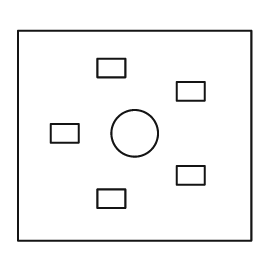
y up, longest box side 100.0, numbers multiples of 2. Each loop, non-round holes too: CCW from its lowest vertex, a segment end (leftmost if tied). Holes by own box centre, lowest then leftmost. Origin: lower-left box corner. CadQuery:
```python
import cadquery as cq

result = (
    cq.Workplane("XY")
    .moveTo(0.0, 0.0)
    .lineTo(100.0, 0.0)
    .lineTo(100.0, 90.0)
    .lineTo(0.0, 90.0)
    .close()
    .moveTo(34.0, 14.0)
    .lineTo(46.0, 14.0)
    .lineTo(46.0, 22.0)
    .lineTo(34.0, 22.0)
    .close()
    .moveTo(68.0, 24.0)
    .lineTo(80.0, 24.0)
    .lineTo(80.0, 32.0)
    .lineTo(68.0, 32.0)
    .close()
    .moveTo(14.0, 42.0)
    .lineTo(26.0, 42.0)
    .lineTo(26.0, 50.0)
    .lineTo(14.0, 50.0)
    .close()
    .moveTo(50.0, 46.0)
    .circle(10.0)
    .moveTo(68.0, 60.0)
    .lineTo(80.0, 60.0)
    .lineTo(80.0, 68.0)
    .lineTo(68.0, 68.0)
    .close()
    .moveTo(34.0, 70.0)
    .lineTo(46.0, 70.0)
    .lineTo(46.0, 78.0)
    .lineTo(34.0, 78.0)
    .close()
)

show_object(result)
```